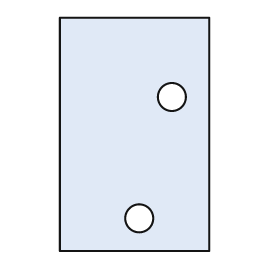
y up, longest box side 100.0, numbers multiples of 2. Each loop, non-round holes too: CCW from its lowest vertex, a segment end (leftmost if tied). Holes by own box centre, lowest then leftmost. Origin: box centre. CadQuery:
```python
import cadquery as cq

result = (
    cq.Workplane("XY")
    .moveTo(-32.0, -50.0)
    .lineTo(32.0, -50.0)
    .lineTo(32.0, 50.0)
    .lineTo(-32.0, 50.0)
    .close()
    .moveTo(2.0, -36.0)
    .circle(6.0)
    .moveTo(16.0, 16.0)
    .circle(6.0)
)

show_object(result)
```